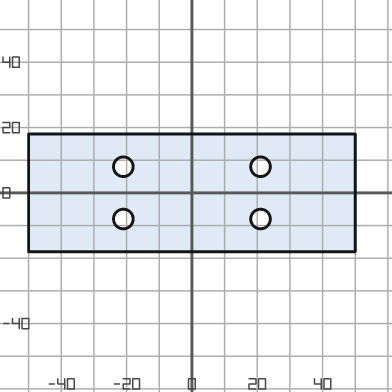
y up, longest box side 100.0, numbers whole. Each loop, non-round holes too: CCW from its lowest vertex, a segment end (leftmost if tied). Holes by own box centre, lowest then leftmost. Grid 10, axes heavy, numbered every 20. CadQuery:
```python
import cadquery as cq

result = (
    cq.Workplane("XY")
    .moveTo(-50.0, -18.0)
    .lineTo(50.0, -18.0)
    .lineTo(50.0, 18.0)
    .lineTo(-50.0, 18.0)
    .close()
    .moveTo(-21.0, -8.0)
    .circle(3.0)
    .moveTo(21.0, -8.0)
    .circle(3.0)
    .moveTo(-21.0, 8.0)
    .circle(3.0)
    .moveTo(21.0, 8.0)
    .circle(3.0)
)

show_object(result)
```